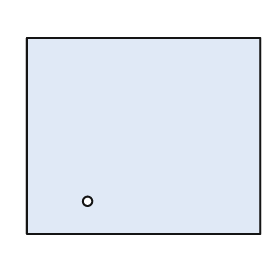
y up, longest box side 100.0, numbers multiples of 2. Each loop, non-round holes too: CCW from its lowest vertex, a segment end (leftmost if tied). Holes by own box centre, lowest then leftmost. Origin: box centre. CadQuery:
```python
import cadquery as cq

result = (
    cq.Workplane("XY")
    .moveTo(-50.0, -42.0)
    .lineTo(50.0, -42.0)
    .lineTo(50.0, 42.0)
    .lineTo(-50.0, 42.0)
    .close()
    .moveTo(-24.0, -28.0)
    .circle(2.0)
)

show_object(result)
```